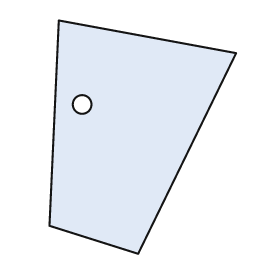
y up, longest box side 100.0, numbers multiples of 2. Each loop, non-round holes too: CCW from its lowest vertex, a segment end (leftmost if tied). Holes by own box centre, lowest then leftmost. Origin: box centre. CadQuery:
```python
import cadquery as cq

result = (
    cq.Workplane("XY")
    .moveTo(-2.0, -50.0)
    .lineTo(40.0, 36.0)
    .lineTo(-36.0, 50.0)
    .lineTo(-40.0, -38.0)
    .close()
    .moveTo(-26.0, 14.0)
    .circle(4.0)
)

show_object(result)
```